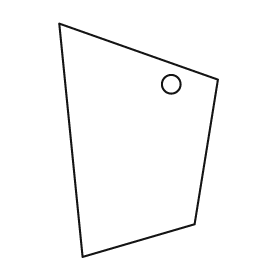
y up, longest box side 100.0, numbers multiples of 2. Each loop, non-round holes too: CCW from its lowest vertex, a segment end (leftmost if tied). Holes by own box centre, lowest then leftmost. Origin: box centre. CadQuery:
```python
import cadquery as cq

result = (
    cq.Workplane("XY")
    .moveTo(-24.0, -50.0)
    .lineTo(24.0, -36.0)
    .lineTo(34.0, 26.0)
    .lineTo(-34.0, 50.0)
    .close()
    .moveTo(14.0, 24.0)
    .circle(4.0)
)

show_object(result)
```